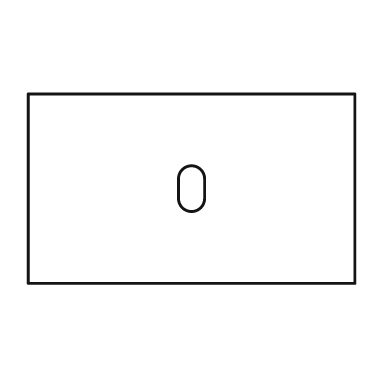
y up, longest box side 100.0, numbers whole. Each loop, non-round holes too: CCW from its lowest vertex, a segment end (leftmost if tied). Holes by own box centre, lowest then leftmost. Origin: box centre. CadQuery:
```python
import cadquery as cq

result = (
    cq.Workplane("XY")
    .moveTo(-50.0, -29.0)
    .lineTo(50.0, -29.0)
    .lineTo(50.0, 29.0)
    .lineTo(-50.0, 29.0)
    .close()
    .moveTo(-4.0, -3.0)
    .threePointArc((0.0, -7.0), (4.0, -3.0))
    .lineTo(4.0, 3.0)
    .threePointArc((0.0, 7.0), (-4.0, 3.0))
    .close()
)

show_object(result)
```